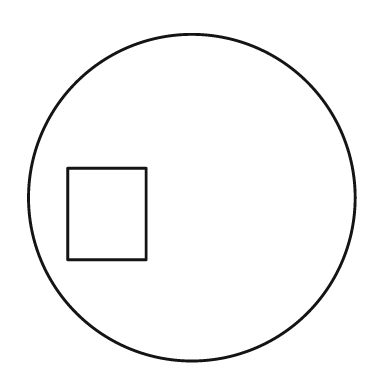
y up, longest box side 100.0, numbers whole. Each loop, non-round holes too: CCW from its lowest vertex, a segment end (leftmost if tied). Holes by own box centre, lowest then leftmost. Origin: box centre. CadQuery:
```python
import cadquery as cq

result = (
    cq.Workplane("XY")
    .moveTo(0.0, 0.0)
    .circle(50.0)
    .moveTo(-38.0, -19.0)
    .lineTo(-14.0, -19.0)
    .lineTo(-14.0, 9.0)
    .lineTo(-38.0, 9.0)
    .close()
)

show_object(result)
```